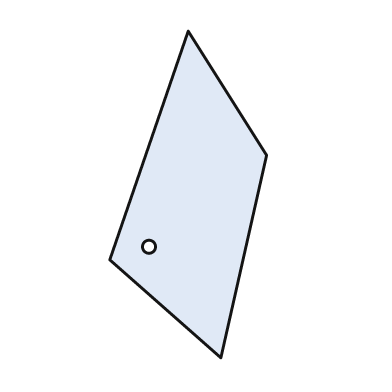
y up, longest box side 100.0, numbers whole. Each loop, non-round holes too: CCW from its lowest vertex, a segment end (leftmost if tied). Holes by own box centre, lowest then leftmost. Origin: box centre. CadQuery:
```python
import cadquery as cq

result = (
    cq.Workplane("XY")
    .moveTo(10.0, -50.0)
    .lineTo(24.0, 12.0)
    .lineTo(0.0, 50.0)
    .lineTo(-24.0, -20.0)
    .close()
    .moveTo(-12.0, -16.0)
    .circle(2.0)
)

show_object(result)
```